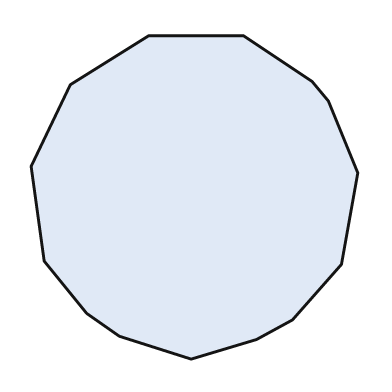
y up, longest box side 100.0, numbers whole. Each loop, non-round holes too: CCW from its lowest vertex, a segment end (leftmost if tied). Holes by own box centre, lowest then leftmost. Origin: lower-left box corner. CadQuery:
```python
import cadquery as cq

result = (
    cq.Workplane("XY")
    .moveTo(49.0, 0.0)
    .lineTo(69.0, 6.0)
    .lineTo(80.0, 12.0)
    .lineTo(95.0, 29.0)
    .lineTo(100.0, 57.0)
    .lineTo(91.0, 79.0)
    .lineTo(86.0, 85.0)
    .lineTo(65.0, 99.0)
    .lineTo(36.0, 99.0)
    .lineTo(12.0, 84.0)
    .lineTo(0.0, 59.0)
    .lineTo(4.0, 30.0)
    .lineTo(17.0, 14.0)
    .lineTo(27.0, 7.0)
    .close()
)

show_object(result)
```